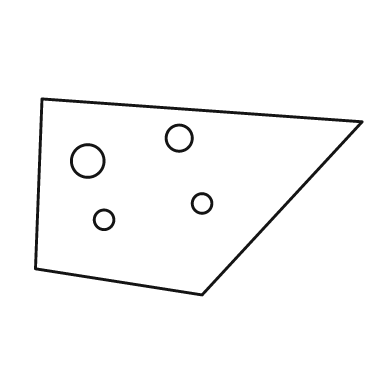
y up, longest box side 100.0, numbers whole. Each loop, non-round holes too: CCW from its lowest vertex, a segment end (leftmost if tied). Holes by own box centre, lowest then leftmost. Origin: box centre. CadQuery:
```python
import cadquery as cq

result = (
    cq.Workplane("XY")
    .moveTo(1.0, -30.0)
    .lineTo(50.0, 23.0)
    .lineTo(-48.0, 30.0)
    .lineTo(-50.0, -22.0)
    .close()
    .moveTo(-29.0, -7.0)
    .circle(3.0)
    .moveTo(1.0, -2.0)
    .circle(3.0)
    .moveTo(-34.0, 11.0)
    .circle(5.0)
    .moveTo(-6.0, 18.0)
    .circle(4.0)
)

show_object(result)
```